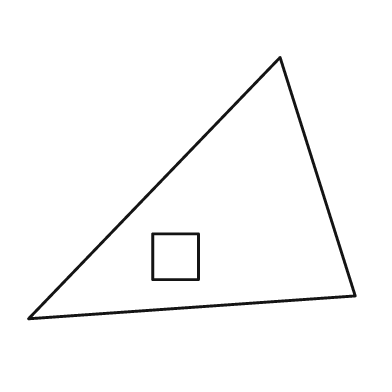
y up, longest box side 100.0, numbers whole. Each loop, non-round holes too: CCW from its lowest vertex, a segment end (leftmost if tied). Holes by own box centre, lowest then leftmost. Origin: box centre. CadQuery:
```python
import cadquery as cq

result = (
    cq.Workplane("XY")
    .moveTo(-50.0, -40.0)
    .lineTo(50.0, -33.0)
    .lineTo(27.0, 40.0)
    .close()
    .moveTo(-12.0, -28.0)
    .lineTo(2.0, -28.0)
    .lineTo(2.0, -14.0)
    .lineTo(-12.0, -14.0)
    .close()
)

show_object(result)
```